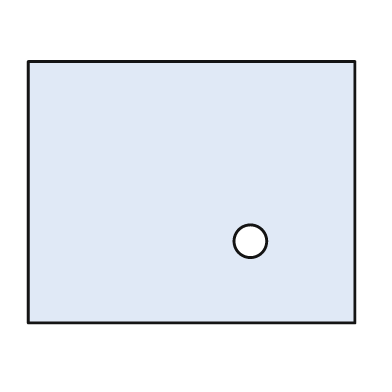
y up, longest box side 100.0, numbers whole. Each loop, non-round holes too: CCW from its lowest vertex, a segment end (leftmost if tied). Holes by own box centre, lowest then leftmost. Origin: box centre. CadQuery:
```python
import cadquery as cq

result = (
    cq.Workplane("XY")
    .moveTo(-50.0, -40.0)
    .lineTo(50.0, -40.0)
    .lineTo(50.0, 40.0)
    .lineTo(-50.0, 40.0)
    .close()
    .moveTo(18.0, -15.0)
    .circle(5.0)
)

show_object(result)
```